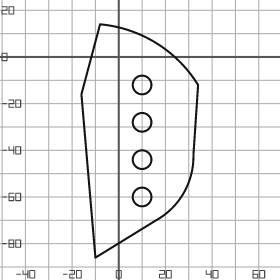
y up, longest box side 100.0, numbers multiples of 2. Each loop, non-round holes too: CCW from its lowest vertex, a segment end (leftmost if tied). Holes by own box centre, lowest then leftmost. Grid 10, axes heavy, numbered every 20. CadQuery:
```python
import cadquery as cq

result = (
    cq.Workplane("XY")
    .moveTo(-10.0, -86.0)
    .lineTo(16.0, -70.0)
    .threePointArc((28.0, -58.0), (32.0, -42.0))
    .lineTo(34.0, -12.0)
    .threePointArc((16.0, 6.0), (-8.0, 14.0))
    .lineTo(-16.0, -16.0)
    .close()
    .moveTo(10.0, -60.0)
    .circle(4.0)
    .moveTo(10.0, -44.0)
    .circle(4.0)
    .moveTo(10.0, -28.0)
    .circle(4.0)
    .moveTo(10.0, -12.0)
    .circle(4.0)
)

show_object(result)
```